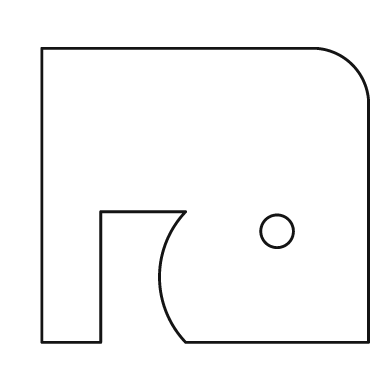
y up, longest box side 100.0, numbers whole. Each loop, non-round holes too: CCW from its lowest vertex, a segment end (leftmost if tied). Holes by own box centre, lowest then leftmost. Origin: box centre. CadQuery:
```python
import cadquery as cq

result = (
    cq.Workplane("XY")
    .moveTo(-50.0, -45.0)
    .lineTo(-32.0, -45.0)
    .lineTo(-32.0, -5.0)
    .lineTo(-6.0, -5.0)
    .threePointArc((-14.0, -25.0), (-6.0, -45.0))
    .lineTo(50.0, -45.0)
    .lineTo(50.0, 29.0)
    .threePointArc((45.0, 40.0), (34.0, 45.0))
    .lineTo(-50.0, 45.0)
    .close()
    .moveTo(22.0, -11.0)
    .circle(5.0)
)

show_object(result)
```